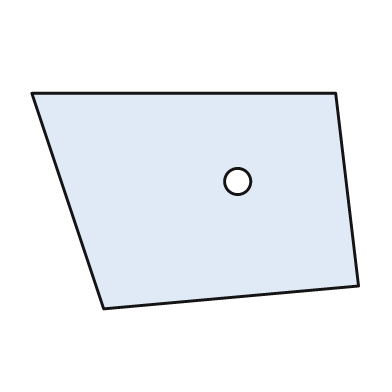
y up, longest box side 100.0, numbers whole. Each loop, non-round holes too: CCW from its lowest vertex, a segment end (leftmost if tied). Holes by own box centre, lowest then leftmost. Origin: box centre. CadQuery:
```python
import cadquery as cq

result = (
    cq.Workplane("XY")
    .moveTo(-28.0, -33.0)
    .lineTo(50.0, -26.0)
    .lineTo(43.0, 33.0)
    .lineTo(-50.0, 33.0)
    .close()
    .moveTo(13.0, 6.0)
    .circle(4.0)
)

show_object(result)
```